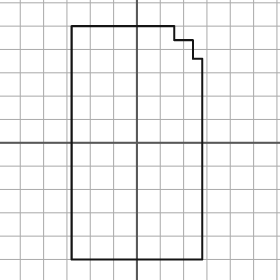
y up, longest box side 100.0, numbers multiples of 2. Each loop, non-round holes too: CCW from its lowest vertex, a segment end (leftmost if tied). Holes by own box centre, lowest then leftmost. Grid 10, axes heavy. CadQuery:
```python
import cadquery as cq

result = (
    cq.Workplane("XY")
    .moveTo(-28.0, -50.0)
    .lineTo(28.0, -50.0)
    .lineTo(28.0, 36.0)
    .lineTo(24.0, 36.0)
    .lineTo(24.0, 44.0)
    .lineTo(16.0, 44.0)
    .lineTo(16.0, 50.0)
    .lineTo(-28.0, 50.0)
    .close()
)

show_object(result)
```